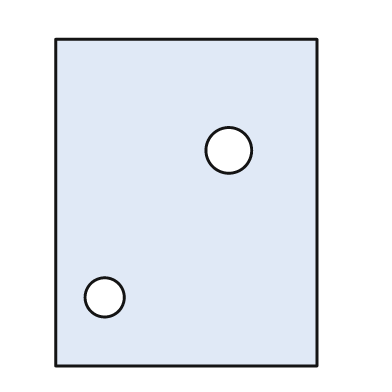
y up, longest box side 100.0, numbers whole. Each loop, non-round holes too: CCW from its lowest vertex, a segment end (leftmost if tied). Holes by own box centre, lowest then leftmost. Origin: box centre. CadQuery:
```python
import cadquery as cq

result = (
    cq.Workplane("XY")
    .moveTo(-40.0, -50.0)
    .lineTo(40.0, -50.0)
    .lineTo(40.0, 50.0)
    .lineTo(-40.0, 50.0)
    .close()
    .moveTo(-25.0, -29.0)
    .circle(6.0)
    .moveTo(13.0, 16.0)
    .circle(7.0)
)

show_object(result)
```